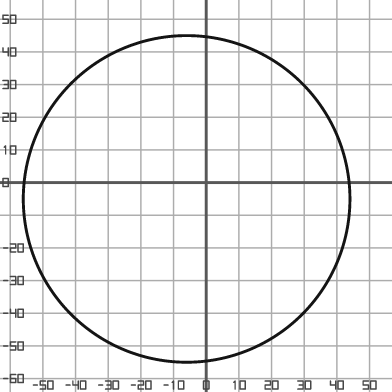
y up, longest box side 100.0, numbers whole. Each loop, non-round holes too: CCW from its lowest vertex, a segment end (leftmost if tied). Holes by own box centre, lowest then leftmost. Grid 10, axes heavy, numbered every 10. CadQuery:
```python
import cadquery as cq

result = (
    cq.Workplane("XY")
    .moveTo(-6.0, -5.0)
    .circle(50.0)
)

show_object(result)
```